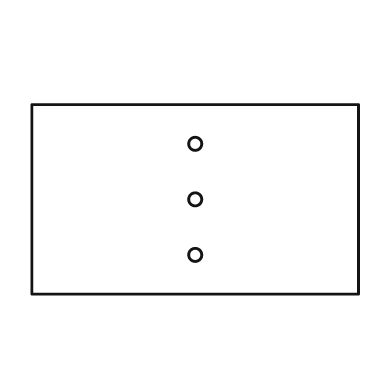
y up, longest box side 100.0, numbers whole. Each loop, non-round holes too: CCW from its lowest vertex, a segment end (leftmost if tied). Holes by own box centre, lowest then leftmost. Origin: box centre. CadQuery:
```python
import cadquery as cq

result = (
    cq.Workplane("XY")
    .moveTo(-50.0, -29.0)
    .lineTo(50.0, -29.0)
    .lineTo(50.0, 29.0)
    .lineTo(-50.0, 29.0)
    .close()
    .moveTo(0.0, -17.0)
    .circle(2.0)
    .moveTo(0.0, 0.0)
    .circle(2.0)
    .moveTo(0.0, 17.0)
    .circle(2.0)
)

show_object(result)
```